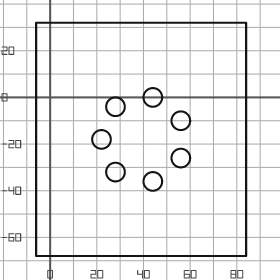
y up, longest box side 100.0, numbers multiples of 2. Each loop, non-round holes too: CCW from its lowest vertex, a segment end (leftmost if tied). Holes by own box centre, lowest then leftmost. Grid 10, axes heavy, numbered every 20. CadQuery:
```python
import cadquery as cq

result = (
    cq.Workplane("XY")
    .moveTo(-6.0, -68.0)
    .lineTo(84.0, -68.0)
    .lineTo(84.0, 32.0)
    .lineTo(-6.0, 32.0)
    .close()
    .moveTo(44.0, -36.0)
    .circle(4.0)
    .moveTo(28.0, -32.0)
    .circle(4.0)
    .moveTo(56.0, -26.0)
    .circle(4.0)
    .moveTo(22.0, -18.0)
    .circle(4.0)
    .moveTo(56.0, -10.0)
    .circle(4.0)
    .moveTo(28.0, -4.0)
    .circle(4.0)
    .moveTo(44.0, 0.0)
    .circle(4.0)
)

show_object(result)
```